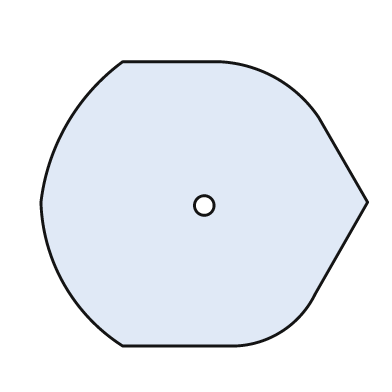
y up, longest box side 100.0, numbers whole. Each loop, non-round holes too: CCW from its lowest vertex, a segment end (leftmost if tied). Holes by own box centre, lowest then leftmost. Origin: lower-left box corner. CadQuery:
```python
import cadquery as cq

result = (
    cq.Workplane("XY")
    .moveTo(25.0, 0.0)
    .lineTo(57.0, 0.0)
    .threePointArc((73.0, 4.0), (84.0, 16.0))
    .lineTo(100.0, 44.0)
    .lineTo(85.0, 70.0)
    .threePointArc((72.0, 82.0), (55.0, 87.0))
    .lineTo(25.0, 87.0)
    .threePointArc((8.0, 68.0), (0.0, 44.0))
    .threePointArc((7.0, 19.0), (25.0, 0.0))
    .close()
    .moveTo(50.0, 43.0)
    .circle(3.0)
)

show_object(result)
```